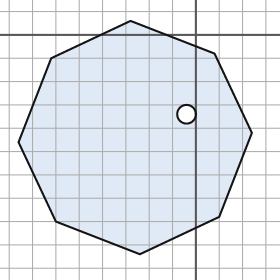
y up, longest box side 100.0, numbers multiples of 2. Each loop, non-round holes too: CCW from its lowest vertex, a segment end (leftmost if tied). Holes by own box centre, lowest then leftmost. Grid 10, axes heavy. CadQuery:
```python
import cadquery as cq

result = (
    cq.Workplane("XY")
    .moveTo(-24.0, -94.0)
    .lineTo(10.0, -78.0)
    .lineTo(24.0, -42.0)
    .lineTo(8.0, -8.0)
    .lineTo(-28.0, 6.0)
    .lineTo(-62.0, -10.0)
    .lineTo(-76.0, -46.0)
    .lineTo(-60.0, -80.0)
    .close()
    .moveTo(-4.0, -34.0)
    .circle(4.0)
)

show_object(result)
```